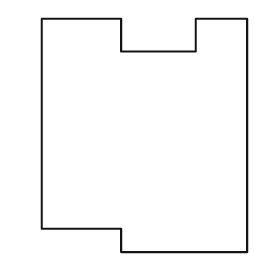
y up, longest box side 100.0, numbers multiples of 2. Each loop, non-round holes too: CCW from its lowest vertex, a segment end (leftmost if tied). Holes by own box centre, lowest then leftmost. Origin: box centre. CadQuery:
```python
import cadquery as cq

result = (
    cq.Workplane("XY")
    .moveTo(-10.0, -50.0)
    .lineTo(44.0, -50.0)
    .lineTo(44.0, 50.0)
    .lineTo(22.0, 50.0)
    .lineTo(22.0, 36.0)
    .lineTo(-10.0, 36.0)
    .lineTo(-10.0, 50.0)
    .lineTo(-44.0, 50.0)
    .lineTo(-44.0, -40.0)
    .lineTo(-10.0, -40.0)
    .close()
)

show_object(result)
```